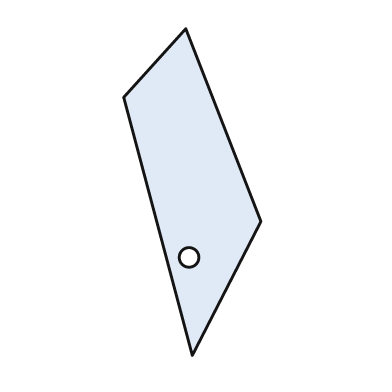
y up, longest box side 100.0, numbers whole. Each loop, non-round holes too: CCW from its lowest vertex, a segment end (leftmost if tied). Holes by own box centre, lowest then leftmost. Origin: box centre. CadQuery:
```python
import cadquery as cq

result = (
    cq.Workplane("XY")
    .moveTo(0.0, -50.0)
    .lineTo(21.0, -9.0)
    .lineTo(-2.0, 50.0)
    .lineTo(-21.0, 29.0)
    .close()
    .moveTo(-1.0, -20.0)
    .circle(3.0)
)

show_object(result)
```